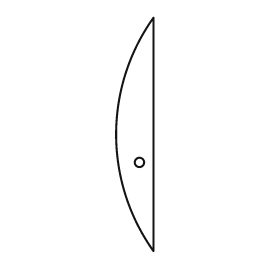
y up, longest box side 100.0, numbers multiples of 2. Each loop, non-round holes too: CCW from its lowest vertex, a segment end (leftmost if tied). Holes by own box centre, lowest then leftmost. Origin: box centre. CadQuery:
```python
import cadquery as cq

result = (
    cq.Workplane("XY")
    .moveTo(8.0, -50.0)
    .lineTo(8.0, 50.0)
    .threePointArc((-8.0, 0.0), (8.0, -50.0))
    .close()
    .moveTo(2.0, -12.0)
    .circle(2.0)
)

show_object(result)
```